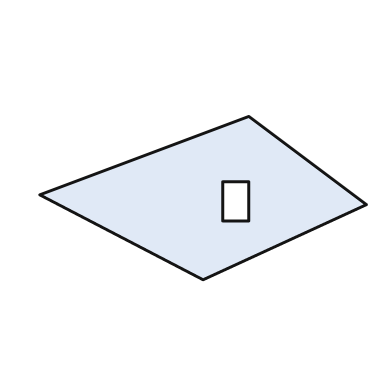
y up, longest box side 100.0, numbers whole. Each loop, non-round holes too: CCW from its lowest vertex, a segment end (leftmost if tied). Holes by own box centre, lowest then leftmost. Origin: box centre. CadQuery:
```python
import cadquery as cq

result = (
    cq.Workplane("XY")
    .moveTo(0.0, -25.0)
    .lineTo(50.0, -2.0)
    .lineTo(14.0, 25.0)
    .lineTo(-50.0, 1.0)
    .close()
    .moveTo(6.0, -7.0)
    .lineTo(14.0, -7.0)
    .lineTo(14.0, 5.0)
    .lineTo(6.0, 5.0)
    .close()
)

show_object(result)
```